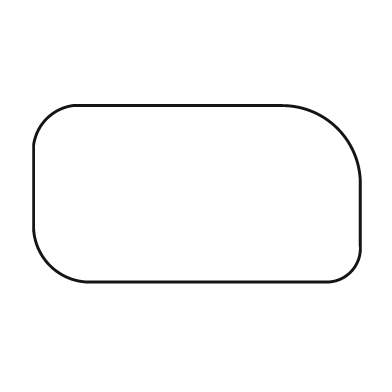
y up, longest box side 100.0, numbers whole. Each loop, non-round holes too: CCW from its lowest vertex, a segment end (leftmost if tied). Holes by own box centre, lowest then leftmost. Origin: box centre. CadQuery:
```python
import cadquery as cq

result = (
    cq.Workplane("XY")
    .moveTo(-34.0, -27.0)
    .lineTo(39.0, -27.0)
    .threePointArc((47.0, -24.0), (50.0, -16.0))
    .lineTo(50.0, 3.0)
    .threePointArc((43.0, 20.0), (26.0, 27.0))
    .lineTo(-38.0, 27.0)
    .threePointArc((-46.0, 23.0), (-50.0, 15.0))
    .lineTo(-50.0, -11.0)
    .threePointArc((-45.0, -22.0), (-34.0, -27.0))
    .close()
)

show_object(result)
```